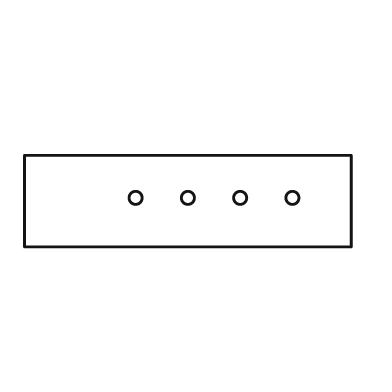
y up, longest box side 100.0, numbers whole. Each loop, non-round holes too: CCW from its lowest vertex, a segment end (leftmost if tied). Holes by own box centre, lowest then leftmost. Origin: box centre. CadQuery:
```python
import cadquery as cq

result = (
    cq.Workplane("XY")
    .moveTo(-50.0, -14.0)
    .lineTo(50.0, -14.0)
    .lineTo(50.0, 14.0)
    .lineTo(-50.0, 14.0)
    .close()
    .moveTo(-16.0, 1.0)
    .circle(2.0)
    .moveTo(0.0, 1.0)
    .circle(2.0)
    .moveTo(16.0, 1.0)
    .circle(2.0)
    .moveTo(32.0, 1.0)
    .circle(2.0)
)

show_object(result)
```